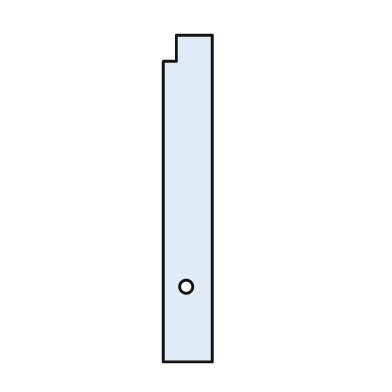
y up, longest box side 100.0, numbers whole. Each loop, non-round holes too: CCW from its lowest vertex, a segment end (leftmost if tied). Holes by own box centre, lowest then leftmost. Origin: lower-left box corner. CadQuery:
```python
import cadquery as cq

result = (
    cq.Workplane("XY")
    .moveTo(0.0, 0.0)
    .lineTo(15.0, 0.0)
    .lineTo(15.0, 100.0)
    .lineTo(4.0, 100.0)
    .lineTo(4.0, 92.0)
    .lineTo(0.0, 92.0)
    .close()
    .moveTo(7.0, 23.0)
    .circle(2.0)
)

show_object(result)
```